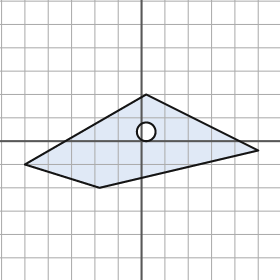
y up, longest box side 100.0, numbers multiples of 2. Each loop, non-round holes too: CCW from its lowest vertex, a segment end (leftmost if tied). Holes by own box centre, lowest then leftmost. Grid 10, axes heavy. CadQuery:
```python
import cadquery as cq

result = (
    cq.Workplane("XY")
    .moveTo(-18.0, -20.0)
    .lineTo(50.0, -4.0)
    .lineTo(2.0, 20.0)
    .lineTo(-50.0, -10.0)
    .close()
    .moveTo(2.0, 4.0)
    .circle(4.0)
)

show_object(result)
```